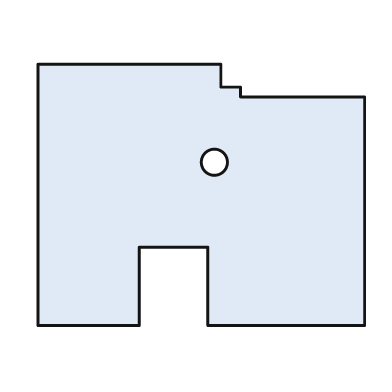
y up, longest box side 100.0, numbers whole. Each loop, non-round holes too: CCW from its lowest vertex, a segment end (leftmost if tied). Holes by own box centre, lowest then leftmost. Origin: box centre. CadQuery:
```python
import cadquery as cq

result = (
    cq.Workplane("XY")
    .moveTo(-50.0, -40.0)
    .lineTo(-19.0, -40.0)
    .lineTo(-19.0, -16.0)
    .lineTo(2.0, -16.0)
    .lineTo(2.0, -40.0)
    .lineTo(50.0, -40.0)
    .lineTo(50.0, 30.0)
    .lineTo(12.0, 30.0)
    .lineTo(12.0, 33.0)
    .lineTo(6.0, 33.0)
    .lineTo(6.0, 40.0)
    .lineTo(-50.0, 40.0)
    .close()
    .moveTo(4.0, 10.0)
    .circle(4.0)
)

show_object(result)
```